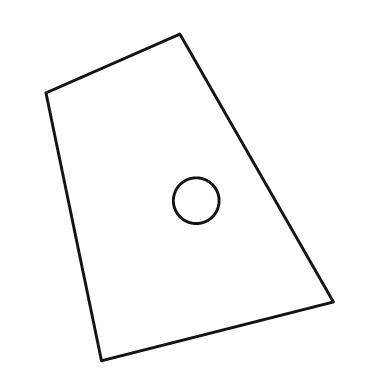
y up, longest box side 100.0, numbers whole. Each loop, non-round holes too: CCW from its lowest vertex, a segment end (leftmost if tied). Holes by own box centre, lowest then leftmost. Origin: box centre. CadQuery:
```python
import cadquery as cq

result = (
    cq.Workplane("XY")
    .moveTo(-27.0, -50.0)
    .lineTo(44.0, -32.0)
    .lineTo(-3.0, 50.0)
    .lineTo(-44.0, 32.0)
    .close()
    .moveTo(2.0, -1.0)
    .circle(7.0)
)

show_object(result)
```